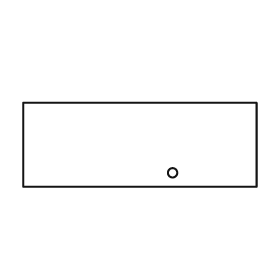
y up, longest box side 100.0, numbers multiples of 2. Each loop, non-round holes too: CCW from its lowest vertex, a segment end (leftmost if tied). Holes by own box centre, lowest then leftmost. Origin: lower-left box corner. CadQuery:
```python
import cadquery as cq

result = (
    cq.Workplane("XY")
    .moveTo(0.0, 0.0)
    .lineTo(100.0, 0.0)
    .lineTo(100.0, 36.0)
    .lineTo(0.0, 36.0)
    .close()
    .moveTo(64.0, 6.0)
    .circle(2.0)
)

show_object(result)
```